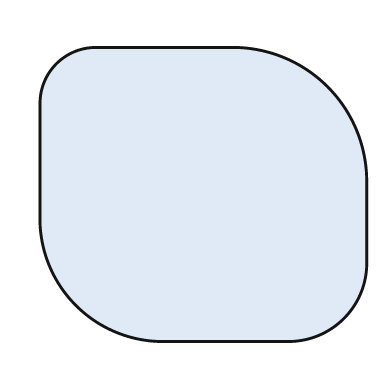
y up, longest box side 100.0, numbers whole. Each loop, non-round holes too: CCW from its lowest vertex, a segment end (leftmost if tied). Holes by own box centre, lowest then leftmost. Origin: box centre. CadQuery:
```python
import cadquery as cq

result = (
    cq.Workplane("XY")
    .moveTo(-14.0, -45.0)
    .lineTo(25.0, -45.0)
    .threePointArc((43.0, -38.0), (50.0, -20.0))
    .lineTo(50.0, 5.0)
    .threePointArc((38.0, 33.0), (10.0, 45.0))
    .lineTo(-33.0, 45.0)
    .threePointArc((-45.0, 40.0), (-50.0, 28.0))
    .lineTo(-50.0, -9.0)
    .threePointArc((-39.0, -34.0), (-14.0, -45.0))
    .close()
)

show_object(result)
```